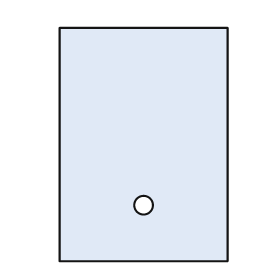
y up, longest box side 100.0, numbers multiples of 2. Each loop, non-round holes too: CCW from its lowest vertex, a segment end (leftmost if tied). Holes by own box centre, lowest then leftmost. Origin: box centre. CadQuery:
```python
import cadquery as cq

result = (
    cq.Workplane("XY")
    .moveTo(-36.0, -50.0)
    .lineTo(36.0, -50.0)
    .lineTo(36.0, 50.0)
    .lineTo(-36.0, 50.0)
    .close()
    .moveTo(0.0, -26.0)
    .circle(4.0)
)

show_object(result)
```